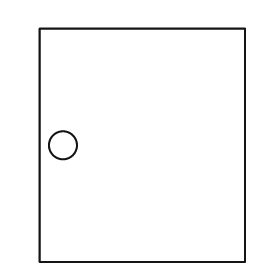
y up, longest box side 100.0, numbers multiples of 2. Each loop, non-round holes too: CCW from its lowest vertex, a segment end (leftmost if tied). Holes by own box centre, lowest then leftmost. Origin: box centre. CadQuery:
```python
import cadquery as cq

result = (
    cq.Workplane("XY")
    .moveTo(-44.0, -50.0)
    .lineTo(44.0, -50.0)
    .lineTo(44.0, 50.0)
    .lineTo(-44.0, 50.0)
    .close()
    .moveTo(-34.0, 0.0)
    .circle(6.0)
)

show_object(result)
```